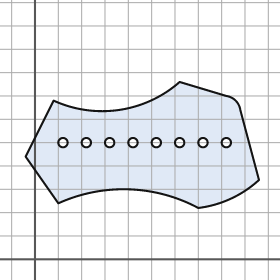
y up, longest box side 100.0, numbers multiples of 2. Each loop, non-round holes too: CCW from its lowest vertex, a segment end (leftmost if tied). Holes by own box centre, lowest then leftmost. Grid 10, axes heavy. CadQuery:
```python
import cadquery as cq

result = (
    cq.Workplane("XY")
    .moveTo(70.0, 22.0)
    .threePointArc((84.0, 26.0), (96.0, 34.0))
    .lineTo(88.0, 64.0)
    .threePointArc((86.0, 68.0), (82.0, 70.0))
    .lineTo(62.0, 76.0)
    .threePointArc((36.0, 64.0), (8.0, 68.0))
    .lineTo(-4.0, 44.0)
    .lineTo(10.0, 24.0)
    .threePointArc((40.0, 30.0), (70.0, 22.0))
    .close()
    .moveTo(12.0, 50.0)
    .circle(2.0)
    .moveTo(22.0, 50.0)
    .circle(2.0)
    .moveTo(32.0, 50.0)
    .circle(2.0)
    .moveTo(42.0, 50.0)
    .circle(2.0)
    .moveTo(52.0, 50.0)
    .circle(2.0)
    .moveTo(62.0, 50.0)
    .circle(2.0)
    .moveTo(72.0, 50.0)
    .circle(2.0)
    .moveTo(82.0, 50.0)
    .circle(2.0)
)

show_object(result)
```